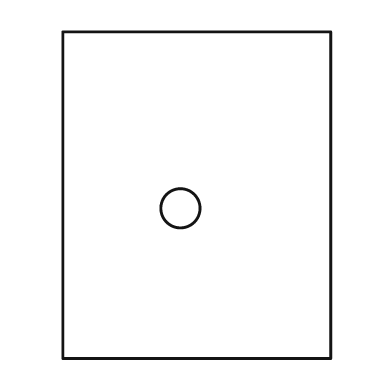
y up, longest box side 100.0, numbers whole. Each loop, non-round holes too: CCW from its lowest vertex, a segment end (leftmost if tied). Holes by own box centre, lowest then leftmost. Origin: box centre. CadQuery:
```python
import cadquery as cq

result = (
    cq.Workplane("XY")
    .moveTo(-41.0, -50.0)
    .lineTo(41.0, -50.0)
    .lineTo(41.0, 50.0)
    .lineTo(-41.0, 50.0)
    .close()
    .moveTo(-5.0, -4.0)
    .circle(6.0)
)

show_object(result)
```